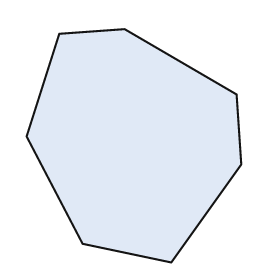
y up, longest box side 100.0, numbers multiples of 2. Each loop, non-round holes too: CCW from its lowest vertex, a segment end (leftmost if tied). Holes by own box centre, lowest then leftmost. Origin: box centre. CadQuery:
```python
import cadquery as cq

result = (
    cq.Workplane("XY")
    .moveTo(16.0, -50.0)
    .lineTo(46.0, -8.0)
    .lineTo(44.0, 22.0)
    .lineTo(-4.0, 50.0)
    .lineTo(-32.0, 48.0)
    .lineTo(-46.0, 4.0)
    .lineTo(-22.0, -42.0)
    .close()
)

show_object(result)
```